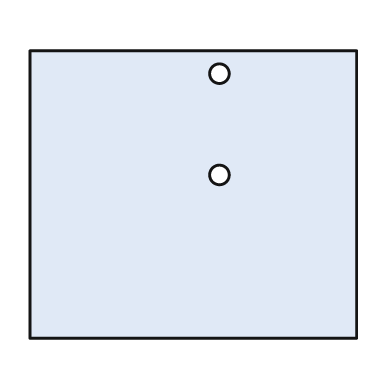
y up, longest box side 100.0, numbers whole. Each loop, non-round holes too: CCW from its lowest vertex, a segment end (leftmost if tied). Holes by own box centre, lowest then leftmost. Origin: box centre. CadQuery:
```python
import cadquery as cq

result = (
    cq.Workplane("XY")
    .moveTo(-50.0, -44.0)
    .lineTo(50.0, -44.0)
    .lineTo(50.0, 44.0)
    .lineTo(-50.0, 44.0)
    .close()
    .moveTo(8.0, 6.0)
    .circle(3.0)
    .moveTo(8.0, 37.0)
    .circle(3.0)
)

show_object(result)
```